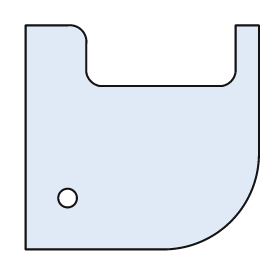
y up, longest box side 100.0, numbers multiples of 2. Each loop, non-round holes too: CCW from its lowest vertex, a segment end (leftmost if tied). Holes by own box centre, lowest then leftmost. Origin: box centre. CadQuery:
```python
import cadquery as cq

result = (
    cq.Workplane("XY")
    .moveTo(-50.0, -48.0)
    .lineTo(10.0, -48.0)
    .threePointArc((38.0, -36.0), (50.0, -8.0))
    .lineTo(50.0, 48.0)
    .lineTo(40.0, 48.0)
    .lineTo(40.0, 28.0)
    .threePointArc((38.0, 24.0), (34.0, 22.0))
    .lineTo(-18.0, 22.0)
    .threePointArc((-22.0, 24.0), (-24.0, 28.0))
    .lineTo(-24.0, 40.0)
    .threePointArc((-26.0, 46.0), (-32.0, 48.0))
    .lineTo(-50.0, 48.0)
    .close()
    .moveTo(-32.0, -26.0)
    .circle(4.0)
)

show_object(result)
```